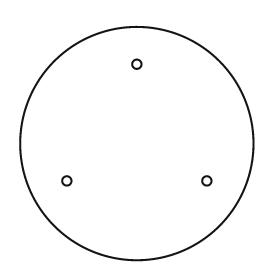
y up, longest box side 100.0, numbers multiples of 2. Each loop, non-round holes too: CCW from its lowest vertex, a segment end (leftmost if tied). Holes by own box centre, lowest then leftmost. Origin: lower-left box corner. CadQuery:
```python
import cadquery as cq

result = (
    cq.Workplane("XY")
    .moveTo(50.0, 50.0)
    .circle(50.0)
    .moveTo(20.0, 34.0)
    .circle(2.0)
    .moveTo(80.0, 34.0)
    .circle(2.0)
    .moveTo(50.0, 84.0)
    .circle(2.0)
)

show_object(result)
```